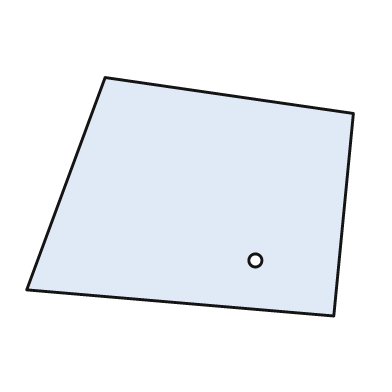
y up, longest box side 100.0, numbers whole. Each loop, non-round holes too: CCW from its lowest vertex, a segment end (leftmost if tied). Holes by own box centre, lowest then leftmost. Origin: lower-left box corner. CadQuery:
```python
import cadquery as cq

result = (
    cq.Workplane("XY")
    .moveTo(94.0, 0.0)
    .lineTo(100.0, 62.0)
    .lineTo(24.0, 73.0)
    .lineTo(0.0, 8.0)
    .close()
    .moveTo(70.0, 17.0)
    .circle(2.0)
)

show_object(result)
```